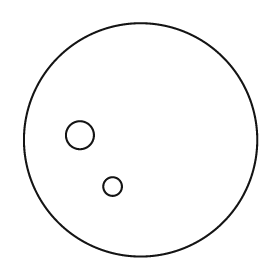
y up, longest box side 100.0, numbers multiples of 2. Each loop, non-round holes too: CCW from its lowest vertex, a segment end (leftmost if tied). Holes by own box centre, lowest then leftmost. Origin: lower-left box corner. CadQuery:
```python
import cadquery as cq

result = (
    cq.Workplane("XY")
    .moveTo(50.0, 50.0)
    .circle(50.0)
    .moveTo(38.0, 30.0)
    .circle(4.0)
    .moveTo(24.0, 52.0)
    .circle(6.0)
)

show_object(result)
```